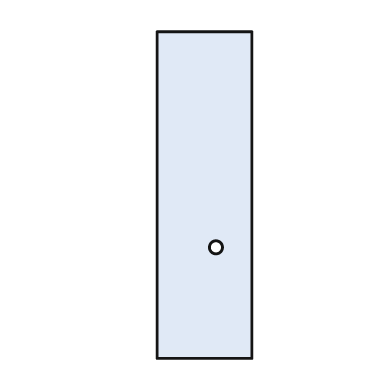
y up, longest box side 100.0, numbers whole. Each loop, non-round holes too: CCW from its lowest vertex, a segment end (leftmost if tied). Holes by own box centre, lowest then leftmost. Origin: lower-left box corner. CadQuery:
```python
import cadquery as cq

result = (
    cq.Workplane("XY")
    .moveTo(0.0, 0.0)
    .lineTo(29.0, 0.0)
    .lineTo(29.0, 100.0)
    .lineTo(0.0, 100.0)
    .close()
    .moveTo(18.0, 34.0)
    .circle(2.0)
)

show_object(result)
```